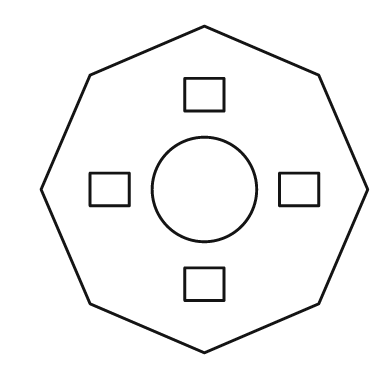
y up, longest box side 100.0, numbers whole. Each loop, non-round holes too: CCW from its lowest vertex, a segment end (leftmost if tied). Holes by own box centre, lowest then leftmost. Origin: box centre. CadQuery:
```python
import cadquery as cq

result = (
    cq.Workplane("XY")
    .moveTo(0.0, -50.0)
    .lineTo(35.0, -35.0)
    .lineTo(50.0, 0.0)
    .lineTo(35.0, 35.0)
    .lineTo(0.0, 50.0)
    .lineTo(-35.0, 35.0)
    .lineTo(-50.0, 0.0)
    .lineTo(-35.0, -35.0)
    .close()
    .moveTo(-6.0, -34.0)
    .lineTo(6.0, -34.0)
    .lineTo(6.0, -24.0)
    .lineTo(-6.0, -24.0)
    .close()
    .moveTo(-35.0, -5.0)
    .lineTo(-23.0, -5.0)
    .lineTo(-23.0, 5.0)
    .lineTo(-35.0, 5.0)
    .close()
    .moveTo(0.0, 0.0)
    .circle(16.0)
    .moveTo(23.0, -5.0)
    .lineTo(35.0, -5.0)
    .lineTo(35.0, 5.0)
    .lineTo(23.0, 5.0)
    .close()
    .moveTo(-6.0, 24.0)
    .lineTo(6.0, 24.0)
    .lineTo(6.0, 34.0)
    .lineTo(-6.0, 34.0)
    .close()
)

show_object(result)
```